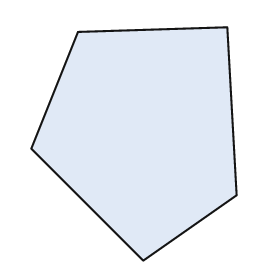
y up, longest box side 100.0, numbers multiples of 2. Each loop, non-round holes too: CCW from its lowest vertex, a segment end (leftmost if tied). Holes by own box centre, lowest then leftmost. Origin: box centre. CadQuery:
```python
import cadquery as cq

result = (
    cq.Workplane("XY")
    .moveTo(4.0, -50.0)
    .lineTo(44.0, -22.0)
    .lineTo(40.0, 50.0)
    .lineTo(-24.0, 48.0)
    .lineTo(-44.0, -2.0)
    .close()
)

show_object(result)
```